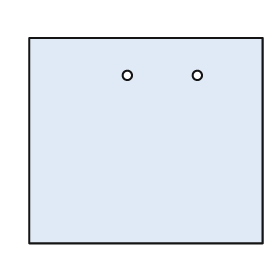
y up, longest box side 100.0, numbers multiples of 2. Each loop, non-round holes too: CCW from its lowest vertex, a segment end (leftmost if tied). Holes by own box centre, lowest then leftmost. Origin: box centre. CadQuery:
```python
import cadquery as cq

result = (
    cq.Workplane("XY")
    .moveTo(-50.0, -44.0)
    .lineTo(50.0, -44.0)
    .lineTo(50.0, 44.0)
    .lineTo(-50.0, 44.0)
    .close()
    .moveTo(-8.0, 28.0)
    .circle(2.0)
    .moveTo(22.0, 28.0)
    .circle(2.0)
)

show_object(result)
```